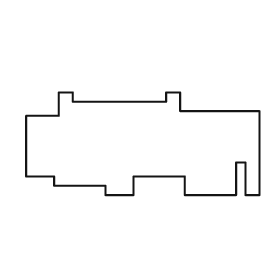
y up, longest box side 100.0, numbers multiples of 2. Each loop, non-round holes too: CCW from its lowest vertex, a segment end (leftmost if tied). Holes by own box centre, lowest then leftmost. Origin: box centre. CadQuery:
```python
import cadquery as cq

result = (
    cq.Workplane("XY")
    .moveTo(-16.0, -22.0)
    .lineTo(-4.0, -22.0)
    .lineTo(-4.0, -14.0)
    .lineTo(18.0, -14.0)
    .lineTo(18.0, -22.0)
    .lineTo(40.0, -22.0)
    .lineTo(40.0, -8.0)
    .lineTo(44.0, -8.0)
    .lineTo(44.0, -22.0)
    .lineTo(50.0, -22.0)
    .lineTo(50.0, 14.0)
    .lineTo(16.0, 14.0)
    .lineTo(16.0, 22.0)
    .lineTo(10.0, 22.0)
    .lineTo(10.0, 18.0)
    .lineTo(-30.0, 18.0)
    .lineTo(-30.0, 22.0)
    .lineTo(-36.0, 22.0)
    .lineTo(-36.0, 12.0)
    .lineTo(-50.0, 12.0)
    .lineTo(-50.0, -14.0)
    .lineTo(-38.0, -14.0)
    .lineTo(-38.0, -18.0)
    .lineTo(-16.0, -18.0)
    .close()
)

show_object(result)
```